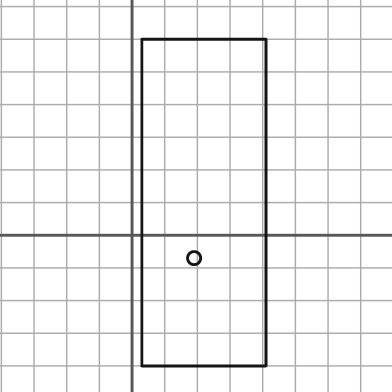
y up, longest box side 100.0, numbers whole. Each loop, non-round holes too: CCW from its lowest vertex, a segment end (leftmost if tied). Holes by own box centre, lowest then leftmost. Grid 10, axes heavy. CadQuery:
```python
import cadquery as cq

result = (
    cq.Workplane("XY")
    .moveTo(3.0, -40.0)
    .lineTo(41.0, -40.0)
    .lineTo(41.0, 60.0)
    .lineTo(3.0, 60.0)
    .close()
    .moveTo(19.0, -7.0)
    .circle(2.0)
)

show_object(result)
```